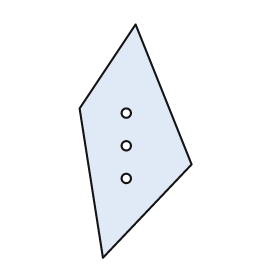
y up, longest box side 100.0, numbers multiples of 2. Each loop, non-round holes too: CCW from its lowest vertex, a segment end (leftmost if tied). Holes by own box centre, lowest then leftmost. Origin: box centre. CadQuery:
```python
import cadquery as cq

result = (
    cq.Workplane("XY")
    .moveTo(-14.0, -50.0)
    .lineTo(24.0, -10.0)
    .lineTo(0.0, 50.0)
    .lineTo(-24.0, 14.0)
    .close()
    .moveTo(-4.0, -16.0)
    .circle(2.0)
    .moveTo(-4.0, -2.0)
    .circle(2.0)
    .moveTo(-4.0, 12.0)
    .circle(2.0)
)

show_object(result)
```